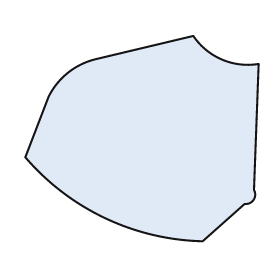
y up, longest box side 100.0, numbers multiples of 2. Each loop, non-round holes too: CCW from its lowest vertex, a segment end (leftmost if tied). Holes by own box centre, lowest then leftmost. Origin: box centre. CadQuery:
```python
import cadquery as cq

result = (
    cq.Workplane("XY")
    .moveTo(26.0, -44.0)
    .lineTo(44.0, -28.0)
    .threePointArc((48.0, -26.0), (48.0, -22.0))
    .lineTo(50.0, 32.0)
    .threePointArc((34.0, 34.0), (22.0, 44.0))
    .lineTo(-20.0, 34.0)
    .threePointArc((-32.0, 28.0), (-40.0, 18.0))
    .lineTo(-50.0, -8.0)
    .threePointArc((-16.0, -34.0), (26.0, -44.0))
    .close()
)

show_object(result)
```